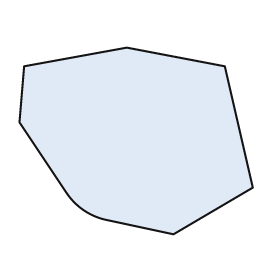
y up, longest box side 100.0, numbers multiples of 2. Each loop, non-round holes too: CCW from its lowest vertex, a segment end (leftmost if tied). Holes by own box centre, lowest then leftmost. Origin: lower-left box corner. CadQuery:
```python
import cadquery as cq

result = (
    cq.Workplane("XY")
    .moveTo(66.0, 0.0)
    .lineTo(100.0, 20.0)
    .lineTo(88.0, 72.0)
    .lineTo(46.0, 80.0)
    .lineTo(2.0, 72.0)
    .lineTo(0.0, 48.0)
    .lineTo(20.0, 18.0)
    .threePointArc((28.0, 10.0), (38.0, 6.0))
    .close()
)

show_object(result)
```